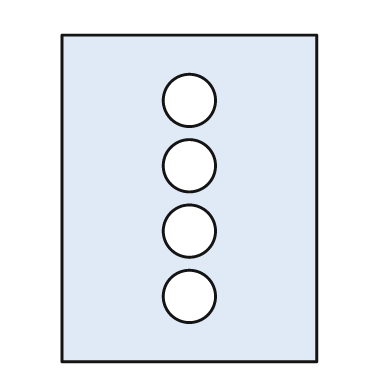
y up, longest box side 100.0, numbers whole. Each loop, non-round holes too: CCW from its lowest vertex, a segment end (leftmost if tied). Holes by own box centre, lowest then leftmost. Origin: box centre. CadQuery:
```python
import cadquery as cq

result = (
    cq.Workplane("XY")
    .moveTo(-39.0, -50.0)
    .lineTo(39.0, -50.0)
    .lineTo(39.0, 50.0)
    .lineTo(-39.0, 50.0)
    .close()
    .moveTo(0.0, -30.0)
    .circle(8.0)
    .moveTo(0.0, -10.0)
    .circle(8.0)
    .moveTo(0.0, 10.0)
    .circle(8.0)
    .moveTo(0.0, 30.0)
    .circle(8.0)
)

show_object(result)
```